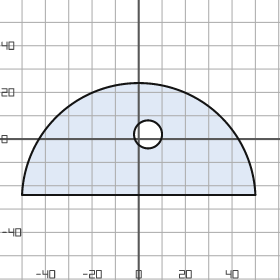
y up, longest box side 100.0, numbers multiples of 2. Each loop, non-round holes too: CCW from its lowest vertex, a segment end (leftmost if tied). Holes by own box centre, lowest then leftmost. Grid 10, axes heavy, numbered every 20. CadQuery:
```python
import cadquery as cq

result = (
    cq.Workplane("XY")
    .moveTo(-50.0, -24.0)
    .lineTo(50.0, -24.0)
    .threePointArc((0.0, 24.0), (-50.0, -24.0))
    .close()
    .moveTo(4.0, 2.0)
    .circle(6.0)
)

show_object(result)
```